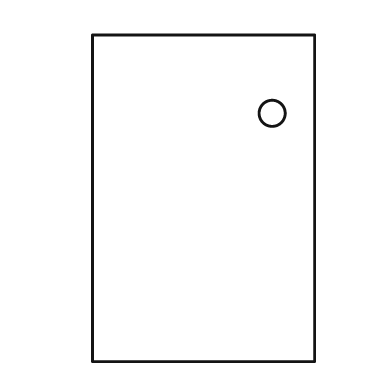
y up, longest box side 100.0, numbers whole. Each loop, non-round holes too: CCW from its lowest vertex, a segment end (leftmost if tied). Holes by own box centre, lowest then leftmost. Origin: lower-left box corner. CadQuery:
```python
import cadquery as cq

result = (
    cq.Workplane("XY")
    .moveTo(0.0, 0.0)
    .lineTo(68.0, 0.0)
    .lineTo(68.0, 100.0)
    .lineTo(0.0, 100.0)
    .close()
    .moveTo(55.0, 76.0)
    .circle(4.0)
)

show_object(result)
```